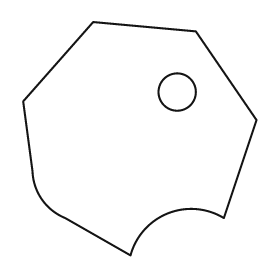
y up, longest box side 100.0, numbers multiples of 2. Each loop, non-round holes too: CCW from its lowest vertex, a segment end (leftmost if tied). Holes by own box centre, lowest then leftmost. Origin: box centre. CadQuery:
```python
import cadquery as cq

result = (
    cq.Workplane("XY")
    .moveTo(-4.0, -50.0)
    .threePointArc((12.0, -32.0), (36.0, -34.0))
    .lineTo(50.0, 8.0)
    .lineTo(24.0, 46.0)
    .lineTo(-20.0, 50.0)
    .lineTo(-50.0, 16.0)
    .lineTo(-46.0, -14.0)
    .threePointArc((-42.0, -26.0), (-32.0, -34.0))
    .close()
    .moveTo(16.0, 20.0)
    .circle(8.0)
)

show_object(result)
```